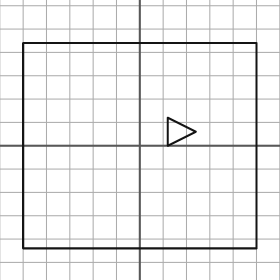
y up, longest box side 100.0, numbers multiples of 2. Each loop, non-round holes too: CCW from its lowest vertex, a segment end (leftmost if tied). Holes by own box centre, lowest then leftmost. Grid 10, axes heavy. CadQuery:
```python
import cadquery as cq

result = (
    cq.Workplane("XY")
    .moveTo(-50.0, -44.0)
    .lineTo(50.0, -44.0)
    .lineTo(50.0, 44.0)
    .lineTo(-50.0, 44.0)
    .close()
    .moveTo(12.0, 0.0)
    .lineTo(24.0, 6.0)
    .lineTo(12.0, 12.0)
    .close()
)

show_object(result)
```